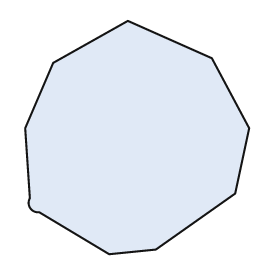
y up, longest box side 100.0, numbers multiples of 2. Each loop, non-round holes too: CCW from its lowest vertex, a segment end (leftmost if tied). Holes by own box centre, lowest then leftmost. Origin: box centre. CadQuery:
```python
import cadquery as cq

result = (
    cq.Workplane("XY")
    .moveTo(-12.0, -50.0)
    .lineTo(8.0, -48.0)
    .lineTo(42.0, -24.0)
    .lineTo(48.0, 4.0)
    .lineTo(32.0, 34.0)
    .lineTo(-4.0, 50.0)
    .lineTo(-36.0, 32.0)
    .lineTo(-48.0, 4.0)
    .lineTo(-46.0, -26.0)
    .threePointArc((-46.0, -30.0), (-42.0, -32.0))
    .close()
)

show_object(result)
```